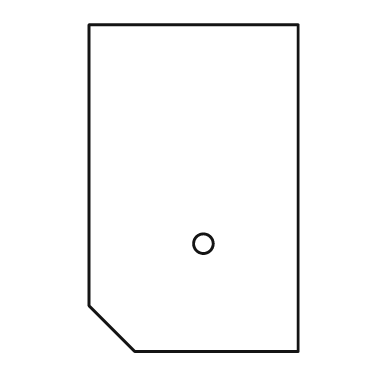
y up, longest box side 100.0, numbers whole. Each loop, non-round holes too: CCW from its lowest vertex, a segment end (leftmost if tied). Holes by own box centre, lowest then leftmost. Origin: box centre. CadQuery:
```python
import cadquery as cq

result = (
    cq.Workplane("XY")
    .moveTo(-18.0, -50.0)
    .lineTo(32.0, -50.0)
    .lineTo(32.0, 50.0)
    .lineTo(-32.0, 50.0)
    .lineTo(-32.0, -36.0)
    .close()
    .moveTo(3.0, -17.0)
    .circle(3.0)
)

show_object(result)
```